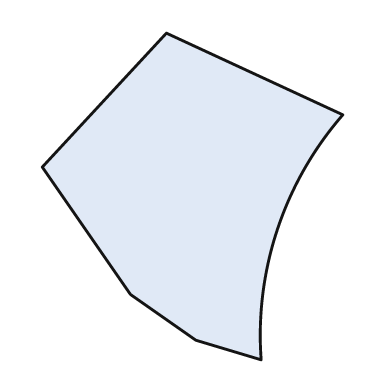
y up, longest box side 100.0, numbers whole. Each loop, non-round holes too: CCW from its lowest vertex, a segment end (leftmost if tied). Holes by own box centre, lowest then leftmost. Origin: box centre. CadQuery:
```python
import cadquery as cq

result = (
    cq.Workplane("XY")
    .moveTo(21.0, -50.0)
    .threePointArc((26.0, -10.0), (46.0, 25.0))
    .lineTo(-8.0, 50.0)
    .lineTo(-46.0, 9.0)
    .lineTo(-19.0, -30.0)
    .lineTo(1.0, -44.0)
    .close()
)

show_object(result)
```